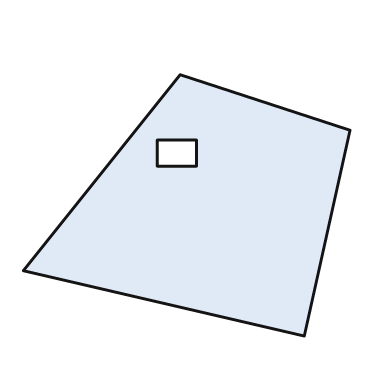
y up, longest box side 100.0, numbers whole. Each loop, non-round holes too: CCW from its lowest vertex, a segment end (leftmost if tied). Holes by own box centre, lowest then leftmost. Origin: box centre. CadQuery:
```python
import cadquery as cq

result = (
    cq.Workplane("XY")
    .moveTo(36.0, -40.0)
    .lineTo(50.0, 23.0)
    .lineTo(-2.0, 40.0)
    .lineTo(-50.0, -20.0)
    .close()
    .moveTo(-9.0, 12.0)
    .lineTo(3.0, 12.0)
    .lineTo(3.0, 20.0)
    .lineTo(-9.0, 20.0)
    .close()
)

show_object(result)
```